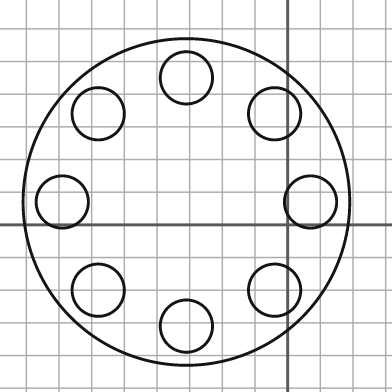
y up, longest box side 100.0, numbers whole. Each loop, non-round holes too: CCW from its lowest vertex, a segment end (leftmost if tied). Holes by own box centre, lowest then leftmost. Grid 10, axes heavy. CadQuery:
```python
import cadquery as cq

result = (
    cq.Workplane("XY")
    .moveTo(-31.0, 7.0)
    .circle(50.0)
    .moveTo(-31.0, -31.0)
    .circle(8.0)
    .moveTo(-58.0, -20.0)
    .circle(8.0)
    .moveTo(-4.0, -20.0)
    .circle(8.0)
    .moveTo(-69.0, 7.0)
    .circle(8.0)
    .moveTo(7.0, 7.0)
    .circle(8.0)
    .moveTo(-58.0, 34.0)
    .circle(8.0)
    .moveTo(-4.0, 34.0)
    .circle(8.0)
    .moveTo(-31.0, 45.0)
    .circle(8.0)
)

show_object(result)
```